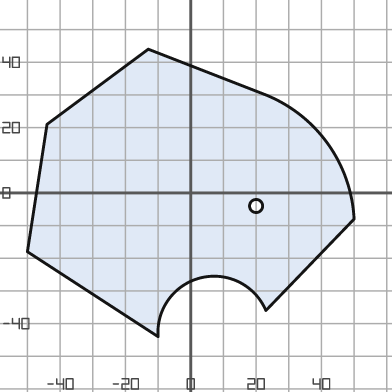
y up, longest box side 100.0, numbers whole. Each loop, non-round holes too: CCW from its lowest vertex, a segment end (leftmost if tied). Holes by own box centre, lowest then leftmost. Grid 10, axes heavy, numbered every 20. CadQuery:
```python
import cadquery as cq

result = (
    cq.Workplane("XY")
    .moveTo(-10.0, -44.0)
    .threePointArc((3.0, -26.0), (23.0, -36.0))
    .lineTo(50.0, -8.0)
    .threePointArc((42.0, 15.0), (23.0, 30.0))
    .lineTo(-13.0, 44.0)
    .lineTo(-44.0, 21.0)
    .lineTo(-50.0, -18.0)
    .close()
    .moveTo(20.0, -4.0)
    .circle(2.0)
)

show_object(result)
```